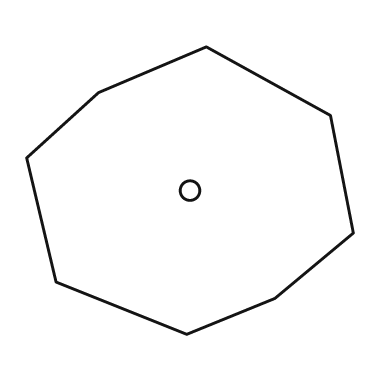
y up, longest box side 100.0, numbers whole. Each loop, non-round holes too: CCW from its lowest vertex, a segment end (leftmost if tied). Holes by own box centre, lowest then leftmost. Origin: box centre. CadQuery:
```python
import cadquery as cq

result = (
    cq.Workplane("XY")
    .moveTo(-1.0, -44.0)
    .lineTo(26.0, -33.0)
    .lineTo(50.0, -13.0)
    .lineTo(43.0, 23.0)
    .lineTo(5.0, 44.0)
    .lineTo(-28.0, 30.0)
    .lineTo(-50.0, 10.0)
    .lineTo(-41.0, -28.0)
    .close()
    .moveTo(0.0, 0.0)
    .circle(3.0)
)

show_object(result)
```